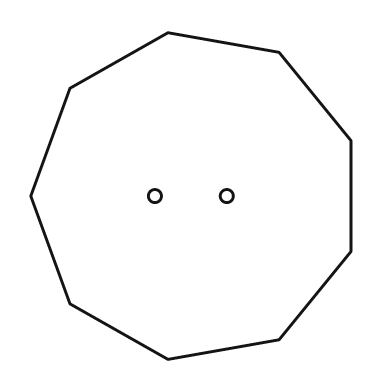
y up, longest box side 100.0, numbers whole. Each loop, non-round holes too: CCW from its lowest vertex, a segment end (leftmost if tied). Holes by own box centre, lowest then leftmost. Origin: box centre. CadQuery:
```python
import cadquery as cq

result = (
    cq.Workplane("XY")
    .moveTo(-7.0, -50.0)
    .lineTo(27.0, -44.0)
    .lineTo(49.0, -17.0)
    .lineTo(49.0, 17.0)
    .lineTo(27.0, 44.0)
    .lineTo(-7.0, 50.0)
    .lineTo(-37.0, 33.0)
    .lineTo(-49.0, 0.0)
    .lineTo(-37.0, -33.0)
    .close()
    .moveTo(-11.0, 0.0)
    .circle(2.0)
    .moveTo(11.0, 0.0)
    .circle(2.0)
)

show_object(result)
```